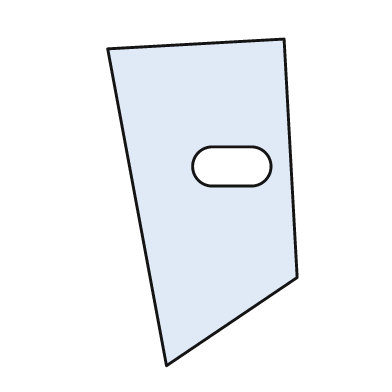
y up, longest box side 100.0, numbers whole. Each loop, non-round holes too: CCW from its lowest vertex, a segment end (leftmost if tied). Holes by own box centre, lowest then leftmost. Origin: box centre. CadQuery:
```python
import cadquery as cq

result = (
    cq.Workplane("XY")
    .moveTo(-11.0, -50.0)
    .lineTo(29.0, -23.0)
    .lineTo(25.0, 50.0)
    .lineTo(-29.0, 47.0)
    .close()
    .moveTo(3.0, 5.0)
    .lineTo(15.0, 5.0)
    .threePointArc((21.0, 11.0), (15.0, 17.0))
    .lineTo(3.0, 17.0)
    .threePointArc((-3.0, 11.0), (3.0, 5.0))
    .close()
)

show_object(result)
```